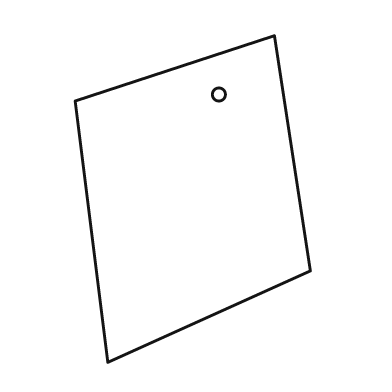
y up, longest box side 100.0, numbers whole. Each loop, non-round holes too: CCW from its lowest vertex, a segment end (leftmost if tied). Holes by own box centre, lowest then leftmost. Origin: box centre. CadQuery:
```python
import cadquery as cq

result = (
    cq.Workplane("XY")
    .moveTo(-26.0, -50.0)
    .lineTo(36.0, -22.0)
    .lineTo(25.0, 50.0)
    .lineTo(-36.0, 30.0)
    .close()
    .moveTo(8.0, 32.0)
    .circle(2.0)
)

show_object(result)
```